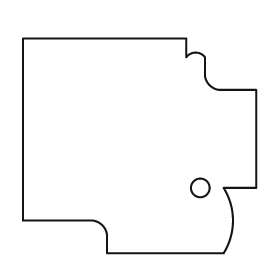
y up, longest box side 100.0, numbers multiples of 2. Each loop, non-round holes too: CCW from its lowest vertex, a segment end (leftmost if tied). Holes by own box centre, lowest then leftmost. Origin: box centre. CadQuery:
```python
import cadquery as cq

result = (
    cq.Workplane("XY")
    .moveTo(-14.0, -46.0)
    .lineTo(36.0, -46.0)
    .threePointArc((40.0, -32.0), (36.0, -18.0))
    .lineTo(50.0, -18.0)
    .lineTo(50.0, 24.0)
    .lineTo(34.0, 24.0)
    .threePointArc((30.0, 26.0), (28.0, 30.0))
    .lineTo(28.0, 38.0)
    .threePointArc((24.0, 40.0), (20.0, 38.0))
    .lineTo(20.0, 46.0)
    .lineTo(-50.0, 46.0)
    .lineTo(-50.0, -32.0)
    .lineTo(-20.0, -32.0)
    .threePointArc((-16.0, -34.0), (-14.0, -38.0))
    .close()
    .moveTo(26.0, -18.0)
    .circle(4.0)
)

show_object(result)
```